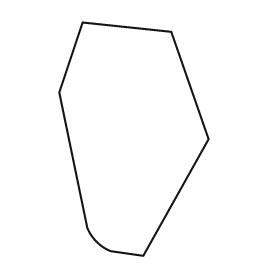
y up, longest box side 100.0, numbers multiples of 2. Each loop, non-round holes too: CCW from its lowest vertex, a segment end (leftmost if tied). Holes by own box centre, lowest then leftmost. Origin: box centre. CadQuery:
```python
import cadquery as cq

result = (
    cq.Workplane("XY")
    .moveTo(4.0, -50.0)
    .lineTo(32.0, 0.0)
    .lineTo(16.0, 46.0)
    .lineTo(-22.0, 50.0)
    .lineTo(-32.0, 20.0)
    .lineTo(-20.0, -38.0)
    .threePointArc((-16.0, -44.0), (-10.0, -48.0))
    .close()
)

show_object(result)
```